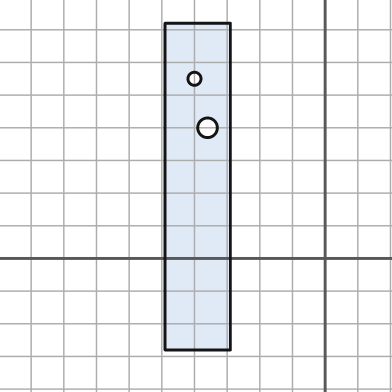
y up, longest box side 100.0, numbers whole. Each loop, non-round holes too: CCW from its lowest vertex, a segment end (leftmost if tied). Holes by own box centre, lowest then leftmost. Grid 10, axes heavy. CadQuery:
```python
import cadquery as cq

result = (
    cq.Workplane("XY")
    .moveTo(-49.0, -28.0)
    .lineTo(-29.0, -28.0)
    .lineTo(-29.0, 72.0)
    .lineTo(-49.0, 72.0)
    .close()
    .moveTo(-36.0, 40.0)
    .circle(3.0)
    .moveTo(-40.0, 55.0)
    .circle(2.0)
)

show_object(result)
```